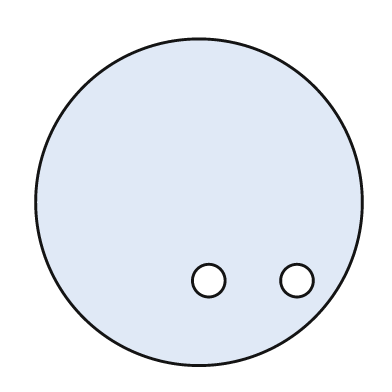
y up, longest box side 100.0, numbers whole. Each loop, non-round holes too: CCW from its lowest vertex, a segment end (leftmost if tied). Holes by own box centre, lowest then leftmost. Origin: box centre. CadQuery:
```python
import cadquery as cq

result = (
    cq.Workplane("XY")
    .moveTo(0.0, 0.0)
    .circle(50.0)
    .moveTo(3.0, -24.0)
    .circle(5.0)
    .moveTo(30.0, -24.0)
    .circle(5.0)
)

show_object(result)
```